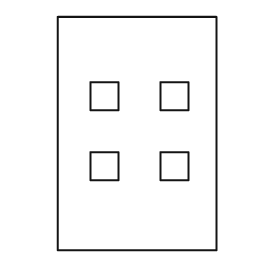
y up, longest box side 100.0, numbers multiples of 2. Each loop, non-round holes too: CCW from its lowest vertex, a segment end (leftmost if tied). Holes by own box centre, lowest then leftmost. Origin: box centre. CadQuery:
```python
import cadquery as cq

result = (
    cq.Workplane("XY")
    .moveTo(-34.0, -50.0)
    .lineTo(34.0, -50.0)
    .lineTo(34.0, 50.0)
    .lineTo(-34.0, 50.0)
    .close()
    .moveTo(-20.0, -20.0)
    .lineTo(-8.0, -20.0)
    .lineTo(-8.0, -8.0)
    .lineTo(-20.0, -8.0)
    .close()
    .moveTo(10.0, -20.0)
    .lineTo(22.0, -20.0)
    .lineTo(22.0, -8.0)
    .lineTo(10.0, -8.0)
    .close()
    .moveTo(-20.0, 10.0)
    .lineTo(-8.0, 10.0)
    .lineTo(-8.0, 22.0)
    .lineTo(-20.0, 22.0)
    .close()
    .moveTo(10.0, 10.0)
    .lineTo(22.0, 10.0)
    .lineTo(22.0, 22.0)
    .lineTo(10.0, 22.0)
    .close()
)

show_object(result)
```